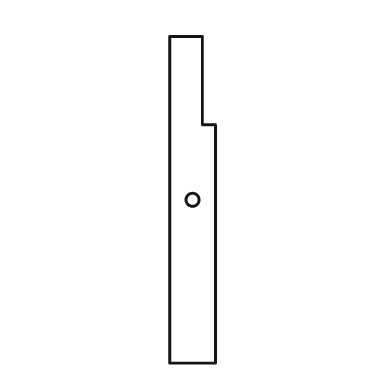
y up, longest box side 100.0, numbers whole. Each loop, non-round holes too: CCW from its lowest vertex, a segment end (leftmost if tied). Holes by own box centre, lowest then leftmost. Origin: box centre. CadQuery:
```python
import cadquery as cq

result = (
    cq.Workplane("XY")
    .moveTo(-7.0, -50.0)
    .lineTo(7.0, -50.0)
    .lineTo(7.0, 23.0)
    .lineTo(3.0, 23.0)
    .lineTo(3.0, 50.0)
    .lineTo(-7.0, 50.0)
    .close()
    .moveTo(0.0, 0.0)
    .circle(2.0)
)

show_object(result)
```